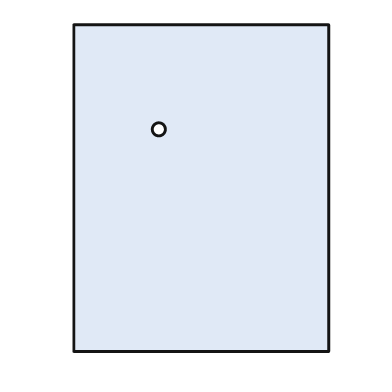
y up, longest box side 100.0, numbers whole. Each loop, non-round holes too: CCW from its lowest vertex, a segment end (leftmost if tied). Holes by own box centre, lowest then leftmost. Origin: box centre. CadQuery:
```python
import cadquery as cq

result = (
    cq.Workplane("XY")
    .moveTo(-39.0, -50.0)
    .lineTo(39.0, -50.0)
    .lineTo(39.0, 50.0)
    .lineTo(-39.0, 50.0)
    .close()
    .moveTo(-13.0, 18.0)
    .circle(2.0)
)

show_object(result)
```